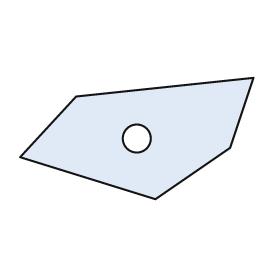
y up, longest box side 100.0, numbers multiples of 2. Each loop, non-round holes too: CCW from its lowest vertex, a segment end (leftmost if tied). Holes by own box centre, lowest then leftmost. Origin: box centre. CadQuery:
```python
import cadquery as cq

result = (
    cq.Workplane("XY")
    .moveTo(8.0, -26.0)
    .lineTo(40.0, -4.0)
    .lineTo(50.0, 26.0)
    .lineTo(-26.0, 18.0)
    .lineTo(-50.0, -8.0)
    .close()
    .moveTo(0.0, 0.0)
    .circle(6.0)
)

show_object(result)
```